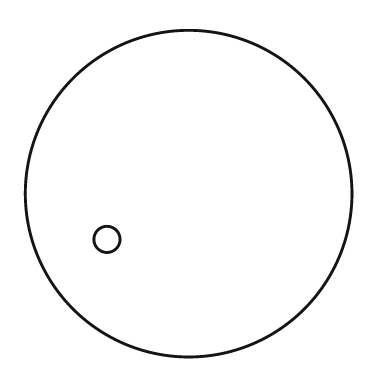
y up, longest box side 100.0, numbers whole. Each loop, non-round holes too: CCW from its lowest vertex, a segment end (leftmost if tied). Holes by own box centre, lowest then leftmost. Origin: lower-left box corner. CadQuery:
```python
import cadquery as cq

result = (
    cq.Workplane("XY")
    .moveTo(50.0, 50.0)
    .circle(50.0)
    .moveTo(25.0, 36.0)
    .circle(4.0)
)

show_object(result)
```